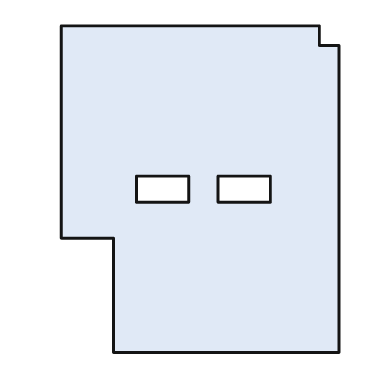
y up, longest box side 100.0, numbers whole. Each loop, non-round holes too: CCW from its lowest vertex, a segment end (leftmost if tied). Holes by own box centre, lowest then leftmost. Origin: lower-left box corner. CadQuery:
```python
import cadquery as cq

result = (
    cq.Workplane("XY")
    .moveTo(16.0, 0.0)
    .lineTo(85.0, 0.0)
    .lineTo(85.0, 94.0)
    .lineTo(79.0, 94.0)
    .lineTo(79.0, 100.0)
    .lineTo(0.0, 100.0)
    .lineTo(0.0, 35.0)
    .lineTo(16.0, 35.0)
    .close()
    .moveTo(23.0, 46.0)
    .lineTo(39.0, 46.0)
    .lineTo(39.0, 54.0)
    .lineTo(23.0, 54.0)
    .close()
    .moveTo(48.0, 46.0)
    .lineTo(64.0, 46.0)
    .lineTo(64.0, 54.0)
    .lineTo(48.0, 54.0)
    .close()
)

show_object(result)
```